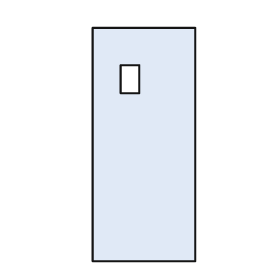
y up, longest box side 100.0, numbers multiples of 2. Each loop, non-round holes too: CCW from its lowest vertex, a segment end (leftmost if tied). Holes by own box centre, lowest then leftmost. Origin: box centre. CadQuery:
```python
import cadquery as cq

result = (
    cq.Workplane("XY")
    .moveTo(-22.0, -50.0)
    .lineTo(22.0, -50.0)
    .lineTo(22.0, 50.0)
    .lineTo(-22.0, 50.0)
    .close()
    .moveTo(-10.0, 22.0)
    .lineTo(-2.0, 22.0)
    .lineTo(-2.0, 34.0)
    .lineTo(-10.0, 34.0)
    .close()
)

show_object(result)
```